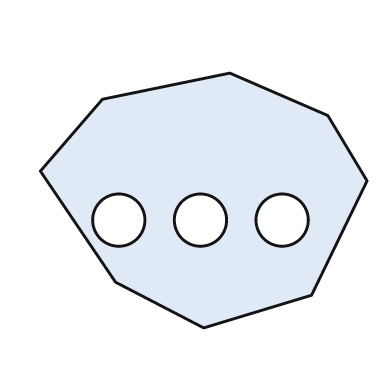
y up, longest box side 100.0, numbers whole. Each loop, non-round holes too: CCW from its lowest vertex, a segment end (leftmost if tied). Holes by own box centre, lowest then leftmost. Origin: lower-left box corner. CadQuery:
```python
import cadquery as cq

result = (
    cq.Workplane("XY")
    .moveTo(50.0, 0.0)
    .lineTo(83.0, 10.0)
    .lineTo(100.0, 45.0)
    .lineTo(88.0, 65.0)
    .lineTo(58.0, 78.0)
    .lineTo(19.0, 70.0)
    .lineTo(0.0, 48.0)
    .lineTo(23.0, 14.0)
    .close()
    .moveTo(24.0, 33.0)
    .circle(8.0)
    .moveTo(49.0, 33.0)
    .circle(8.0)
    .moveTo(74.0, 33.0)
    .circle(8.0)
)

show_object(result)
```